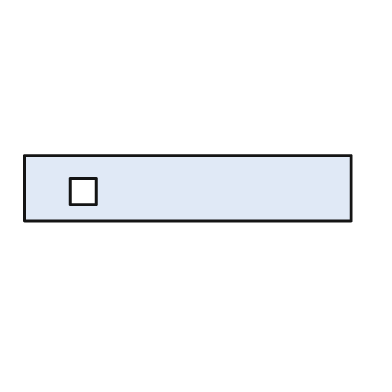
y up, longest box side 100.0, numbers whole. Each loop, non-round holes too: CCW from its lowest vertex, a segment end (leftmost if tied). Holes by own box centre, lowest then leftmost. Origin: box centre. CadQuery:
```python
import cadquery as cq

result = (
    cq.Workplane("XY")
    .moveTo(-50.0, -10.0)
    .lineTo(50.0, -10.0)
    .lineTo(50.0, 10.0)
    .lineTo(-50.0, 10.0)
    .close()
    .moveTo(-36.0, -5.0)
    .lineTo(-28.0, -5.0)
    .lineTo(-28.0, 3.0)
    .lineTo(-36.0, 3.0)
    .close()
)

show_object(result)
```